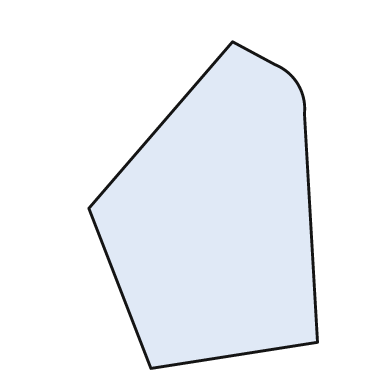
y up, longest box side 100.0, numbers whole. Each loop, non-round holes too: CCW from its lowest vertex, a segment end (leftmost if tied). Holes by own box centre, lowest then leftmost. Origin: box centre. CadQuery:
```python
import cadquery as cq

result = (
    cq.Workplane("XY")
    .moveTo(-16.0, -50.0)
    .lineTo(35.0, -42.0)
    .lineTo(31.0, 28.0)
    .threePointArc((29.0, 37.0), (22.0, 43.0))
    .lineTo(9.0, 50.0)
    .lineTo(-35.0, -1.0)
    .close()
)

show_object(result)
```